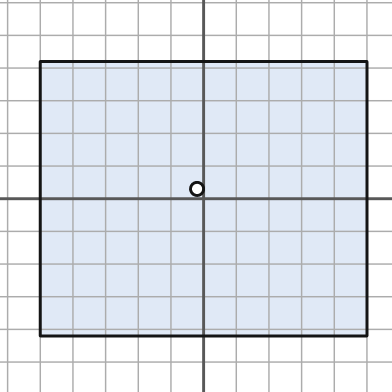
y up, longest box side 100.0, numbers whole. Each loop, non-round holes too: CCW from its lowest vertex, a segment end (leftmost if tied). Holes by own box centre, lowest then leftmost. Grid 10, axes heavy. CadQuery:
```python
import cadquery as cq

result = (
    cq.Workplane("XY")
    .moveTo(-50.0, -42.0)
    .lineTo(50.0, -42.0)
    .lineTo(50.0, 42.0)
    .lineTo(-50.0, 42.0)
    .close()
    .moveTo(-2.0, 3.0)
    .circle(2.0)
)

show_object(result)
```